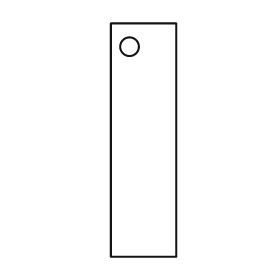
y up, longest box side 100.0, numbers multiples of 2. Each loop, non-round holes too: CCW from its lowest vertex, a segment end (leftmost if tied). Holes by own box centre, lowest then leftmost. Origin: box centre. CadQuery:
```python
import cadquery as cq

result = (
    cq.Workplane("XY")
    .moveTo(-14.0, -50.0)
    .lineTo(14.0, -50.0)
    .lineTo(14.0, 50.0)
    .lineTo(-14.0, 50.0)
    .close()
    .moveTo(-6.0, 40.0)
    .circle(4.0)
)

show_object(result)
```